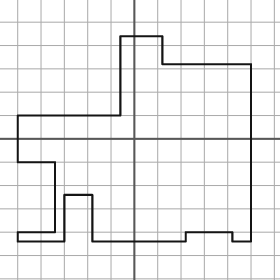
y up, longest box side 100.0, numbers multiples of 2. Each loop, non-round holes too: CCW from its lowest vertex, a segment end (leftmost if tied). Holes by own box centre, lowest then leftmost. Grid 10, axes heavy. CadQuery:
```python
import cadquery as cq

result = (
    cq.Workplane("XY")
    .moveTo(-50.0, -44.0)
    .lineTo(-30.0, -44.0)
    .lineTo(-30.0, -24.0)
    .lineTo(-18.0, -24.0)
    .lineTo(-18.0, -44.0)
    .lineTo(22.0, -44.0)
    .lineTo(22.0, -40.0)
    .lineTo(42.0, -40.0)
    .lineTo(42.0, -44.0)
    .lineTo(50.0, -44.0)
    .lineTo(50.0, 32.0)
    .lineTo(12.0, 32.0)
    .lineTo(12.0, 44.0)
    .lineTo(-6.0, 44.0)
    .lineTo(-6.0, 10.0)
    .lineTo(-50.0, 10.0)
    .lineTo(-50.0, -10.0)
    .lineTo(-34.0, -10.0)
    .lineTo(-34.0, -40.0)
    .lineTo(-50.0, -40.0)
    .close()
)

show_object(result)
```